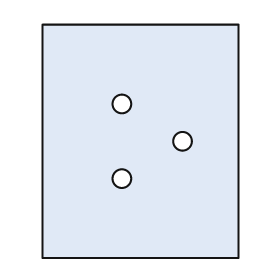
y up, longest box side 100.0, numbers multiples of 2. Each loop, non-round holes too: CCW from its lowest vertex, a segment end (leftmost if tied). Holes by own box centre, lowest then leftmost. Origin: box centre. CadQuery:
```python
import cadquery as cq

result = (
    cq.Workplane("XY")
    .moveTo(-42.0, -50.0)
    .lineTo(42.0, -50.0)
    .lineTo(42.0, 50.0)
    .lineTo(-42.0, 50.0)
    .close()
    .moveTo(-8.0, -16.0)
    .circle(4.0)
    .moveTo(18.0, 0.0)
    .circle(4.0)
    .moveTo(-8.0, 16.0)
    .circle(4.0)
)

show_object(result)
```